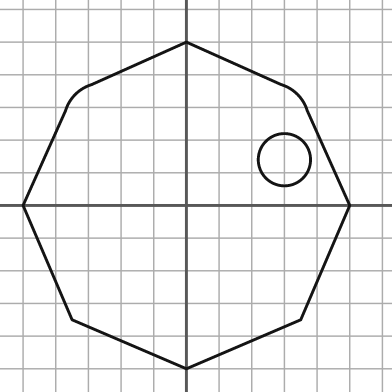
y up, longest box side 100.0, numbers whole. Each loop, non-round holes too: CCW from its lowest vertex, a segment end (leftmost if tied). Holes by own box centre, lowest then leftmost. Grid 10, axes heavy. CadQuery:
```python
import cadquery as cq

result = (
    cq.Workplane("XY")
    .moveTo(0.0, -50.0)
    .lineTo(35.0, -35.0)
    .lineTo(50.0, 0.0)
    .lineTo(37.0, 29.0)
    .threePointArc((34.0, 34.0), (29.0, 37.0))
    .lineTo(0.0, 50.0)
    .lineTo(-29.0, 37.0)
    .threePointArc((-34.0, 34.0), (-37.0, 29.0))
    .lineTo(-50.0, 0.0)
    .lineTo(-35.0, -35.0)
    .close()
    .moveTo(30.0, 14.0)
    .circle(8.0)
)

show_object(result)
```